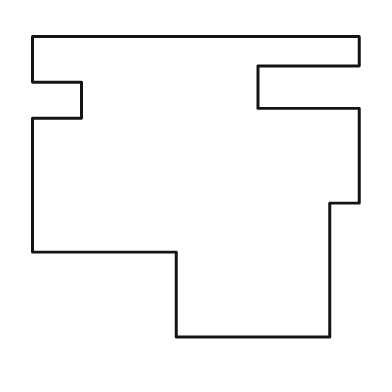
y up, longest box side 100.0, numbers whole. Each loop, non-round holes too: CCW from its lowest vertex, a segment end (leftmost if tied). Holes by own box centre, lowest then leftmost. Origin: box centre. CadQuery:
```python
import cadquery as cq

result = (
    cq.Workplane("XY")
    .moveTo(-6.0, -46.0)
    .lineTo(41.0, -46.0)
    .lineTo(41.0, -5.0)
    .lineTo(50.0, -5.0)
    .lineTo(50.0, 24.0)
    .lineTo(19.0, 24.0)
    .lineTo(19.0, 37.0)
    .lineTo(50.0, 37.0)
    .lineTo(50.0, 46.0)
    .lineTo(-50.0, 46.0)
    .lineTo(-50.0, 32.0)
    .lineTo(-35.0, 32.0)
    .lineTo(-35.0, 21.0)
    .lineTo(-50.0, 21.0)
    .lineTo(-50.0, -20.0)
    .lineTo(-6.0, -20.0)
    .close()
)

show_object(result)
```